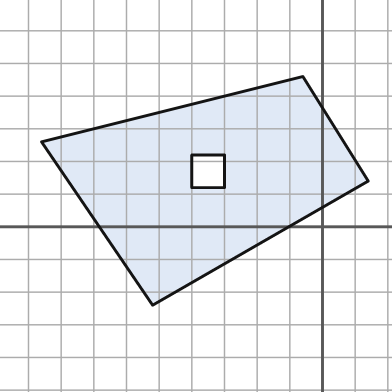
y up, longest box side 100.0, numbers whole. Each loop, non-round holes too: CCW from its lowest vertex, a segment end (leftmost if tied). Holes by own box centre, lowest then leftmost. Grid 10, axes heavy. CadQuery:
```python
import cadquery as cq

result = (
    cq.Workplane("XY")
    .moveTo(-52.0, -24.0)
    .lineTo(14.0, 14.0)
    .lineTo(-6.0, 46.0)
    .lineTo(-86.0, 26.0)
    .close()
    .moveTo(-40.0, 12.0)
    .lineTo(-30.0, 12.0)
    .lineTo(-30.0, 22.0)
    .lineTo(-40.0, 22.0)
    .close()
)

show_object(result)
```